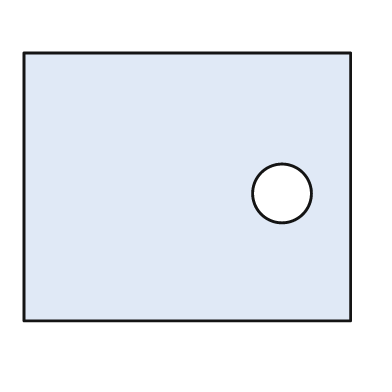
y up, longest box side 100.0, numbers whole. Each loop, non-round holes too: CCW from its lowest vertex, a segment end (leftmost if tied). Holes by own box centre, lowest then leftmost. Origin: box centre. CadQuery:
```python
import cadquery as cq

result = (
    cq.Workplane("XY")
    .moveTo(-50.0, -41.0)
    .lineTo(50.0, -41.0)
    .lineTo(50.0, 41.0)
    .lineTo(-50.0, 41.0)
    .close()
    .moveTo(29.0, -2.0)
    .circle(9.0)
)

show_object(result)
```